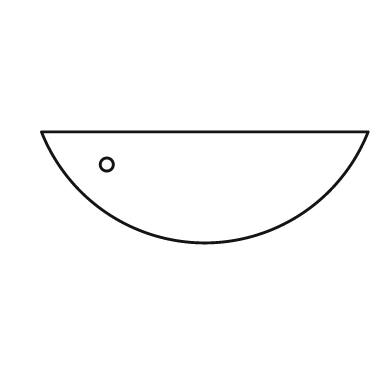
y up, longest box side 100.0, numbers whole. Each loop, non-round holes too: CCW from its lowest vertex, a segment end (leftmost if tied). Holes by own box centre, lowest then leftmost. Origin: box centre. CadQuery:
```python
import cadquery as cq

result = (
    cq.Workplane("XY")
    .moveTo(-50.0, 17.0)
    .threePointArc((0.0, -17.0), (50.0, 17.0))
    .close()
    .moveTo(-30.0, 7.0)
    .circle(2.0)
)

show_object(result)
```